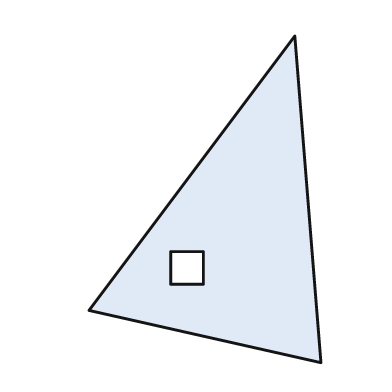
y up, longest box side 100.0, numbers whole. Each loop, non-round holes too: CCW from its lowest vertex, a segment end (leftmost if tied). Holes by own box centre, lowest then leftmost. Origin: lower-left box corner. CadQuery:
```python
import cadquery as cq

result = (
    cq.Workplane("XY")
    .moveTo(71.0, 0.0)
    .lineTo(63.0, 100.0)
    .lineTo(0.0, 16.0)
    .close()
    .moveTo(25.0, 24.0)
    .lineTo(35.0, 24.0)
    .lineTo(35.0, 34.0)
    .lineTo(25.0, 34.0)
    .close()
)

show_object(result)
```